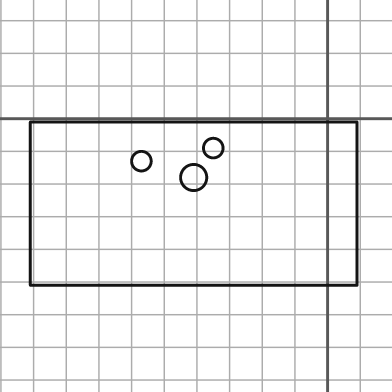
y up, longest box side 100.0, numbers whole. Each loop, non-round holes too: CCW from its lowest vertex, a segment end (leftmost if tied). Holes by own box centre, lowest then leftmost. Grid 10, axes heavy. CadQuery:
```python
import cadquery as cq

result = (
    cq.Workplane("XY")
    .moveTo(-91.0, -51.0)
    .lineTo(9.0, -51.0)
    .lineTo(9.0, -1.0)
    .lineTo(-91.0, -1.0)
    .close()
    .moveTo(-41.0, -18.0)
    .circle(4.0)
    .moveTo(-57.0, -13.0)
    .circle(3.0)
    .moveTo(-35.0, -9.0)
    .circle(3.0)
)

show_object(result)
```